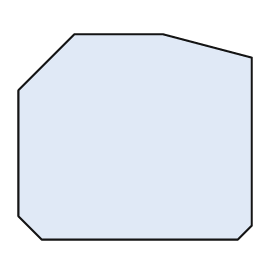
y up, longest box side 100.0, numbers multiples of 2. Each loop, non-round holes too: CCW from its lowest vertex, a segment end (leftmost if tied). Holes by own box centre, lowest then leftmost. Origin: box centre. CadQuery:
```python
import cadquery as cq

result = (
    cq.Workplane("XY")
    .moveTo(-40.0, -44.0)
    .lineTo(44.0, -44.0)
    .lineTo(50.0, -38.0)
    .lineTo(50.0, 34.0)
    .lineTo(12.0, 44.0)
    .lineTo(-26.0, 44.0)
    .lineTo(-50.0, 20.0)
    .lineTo(-50.0, -34.0)
    .close()
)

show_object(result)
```